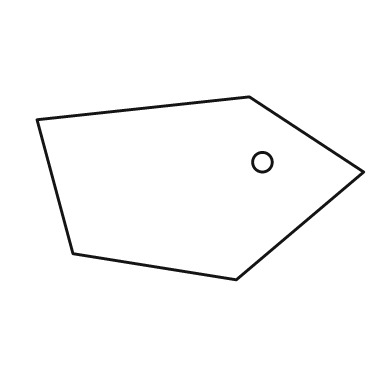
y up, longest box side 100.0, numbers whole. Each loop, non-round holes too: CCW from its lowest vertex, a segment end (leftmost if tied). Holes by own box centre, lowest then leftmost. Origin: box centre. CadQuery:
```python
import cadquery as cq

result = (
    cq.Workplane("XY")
    .moveTo(11.0, -28.0)
    .lineTo(50.0, 5.0)
    .lineTo(15.0, 28.0)
    .lineTo(-50.0, 21.0)
    .lineTo(-39.0, -20.0)
    .close()
    .moveTo(19.0, 8.0)
    .circle(3.0)
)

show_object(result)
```